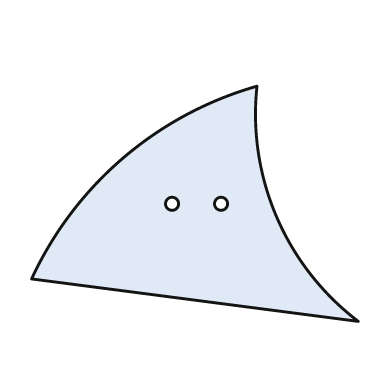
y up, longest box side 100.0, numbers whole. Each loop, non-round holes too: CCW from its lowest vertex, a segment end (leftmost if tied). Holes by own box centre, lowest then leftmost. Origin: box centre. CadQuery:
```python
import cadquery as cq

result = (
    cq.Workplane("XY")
    .moveTo(50.0, -36.0)
    .threePointArc((25.0, -4.0), (19.0, 36.0))
    .threePointArc((-22.0, 14.0), (-50.0, -23.0))
    .close()
    .moveTo(-7.0, 0.0)
    .circle(2.0)
    .moveTo(8.0, 0.0)
    .circle(2.0)
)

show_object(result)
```